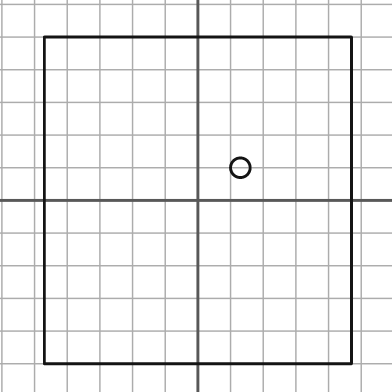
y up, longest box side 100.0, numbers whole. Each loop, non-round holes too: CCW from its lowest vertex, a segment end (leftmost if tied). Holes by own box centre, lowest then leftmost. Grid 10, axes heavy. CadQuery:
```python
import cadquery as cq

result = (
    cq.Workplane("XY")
    .moveTo(-47.0, -50.0)
    .lineTo(47.0, -50.0)
    .lineTo(47.0, 50.0)
    .lineTo(-47.0, 50.0)
    .close()
    .moveTo(13.0, 10.0)
    .circle(3.0)
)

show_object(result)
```